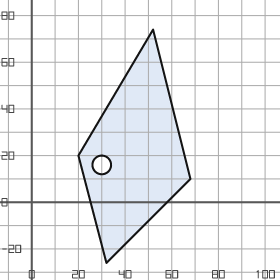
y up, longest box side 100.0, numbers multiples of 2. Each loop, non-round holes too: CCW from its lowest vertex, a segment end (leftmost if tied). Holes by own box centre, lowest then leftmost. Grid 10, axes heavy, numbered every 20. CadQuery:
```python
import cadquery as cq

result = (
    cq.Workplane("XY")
    .moveTo(32.0, -26.0)
    .lineTo(68.0, 10.0)
    .lineTo(52.0, 74.0)
    .lineTo(20.0, 20.0)
    .close()
    .moveTo(30.0, 16.0)
    .circle(4.0)
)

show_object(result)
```